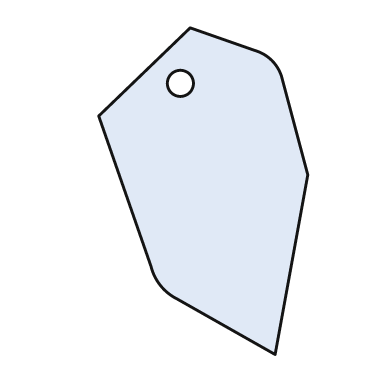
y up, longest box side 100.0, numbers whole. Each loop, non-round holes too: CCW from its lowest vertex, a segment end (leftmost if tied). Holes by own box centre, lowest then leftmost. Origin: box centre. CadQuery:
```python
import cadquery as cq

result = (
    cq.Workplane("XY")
    .moveTo(22.0, -50.0)
    .lineTo(32.0, 5.0)
    .lineTo(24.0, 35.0)
    .threePointArc((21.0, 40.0), (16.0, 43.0))
    .lineTo(-4.0, 50.0)
    .lineTo(-32.0, 23.0)
    .lineTo(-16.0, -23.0)
    .threePointArc((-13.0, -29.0), (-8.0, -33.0))
    .close()
    .moveTo(-7.0, 33.0)
    .circle(4.0)
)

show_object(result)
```